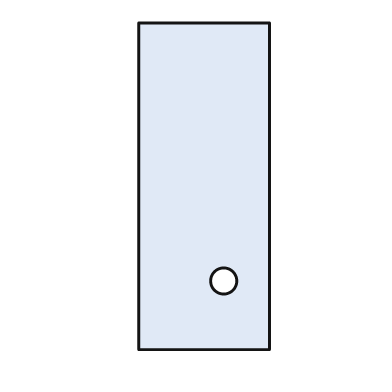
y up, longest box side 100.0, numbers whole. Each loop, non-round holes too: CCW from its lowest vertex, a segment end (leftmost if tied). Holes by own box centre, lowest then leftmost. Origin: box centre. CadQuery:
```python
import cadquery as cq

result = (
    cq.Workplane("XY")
    .moveTo(-20.0, -50.0)
    .lineTo(20.0, -50.0)
    .lineTo(20.0, 50.0)
    .lineTo(-20.0, 50.0)
    .close()
    .moveTo(6.0, -29.0)
    .circle(4.0)
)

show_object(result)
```